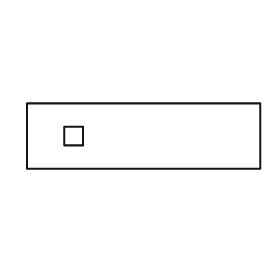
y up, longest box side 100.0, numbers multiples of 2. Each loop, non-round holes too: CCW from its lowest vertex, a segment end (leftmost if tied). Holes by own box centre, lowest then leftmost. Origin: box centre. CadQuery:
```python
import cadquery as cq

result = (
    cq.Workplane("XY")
    .moveTo(-50.0, -14.0)
    .lineTo(50.0, -14.0)
    .lineTo(50.0, 14.0)
    .lineTo(-50.0, 14.0)
    .close()
    .moveTo(-34.0, -4.0)
    .lineTo(-26.0, -4.0)
    .lineTo(-26.0, 4.0)
    .lineTo(-34.0, 4.0)
    .close()
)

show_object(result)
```